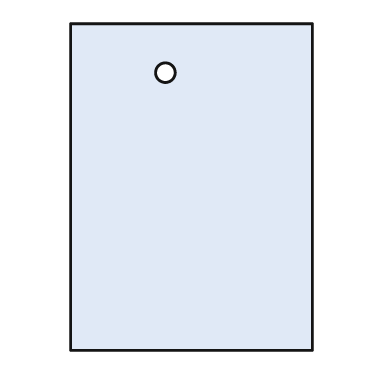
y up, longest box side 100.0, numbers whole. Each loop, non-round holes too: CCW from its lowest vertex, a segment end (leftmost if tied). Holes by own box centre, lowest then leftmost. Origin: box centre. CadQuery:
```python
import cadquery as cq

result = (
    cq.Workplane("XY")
    .moveTo(-37.0, -50.0)
    .lineTo(37.0, -50.0)
    .lineTo(37.0, 50.0)
    .lineTo(-37.0, 50.0)
    .close()
    .moveTo(-8.0, 35.0)
    .circle(3.0)
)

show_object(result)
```